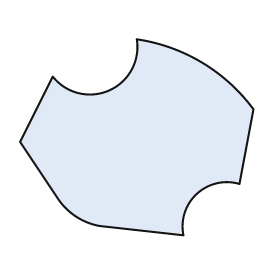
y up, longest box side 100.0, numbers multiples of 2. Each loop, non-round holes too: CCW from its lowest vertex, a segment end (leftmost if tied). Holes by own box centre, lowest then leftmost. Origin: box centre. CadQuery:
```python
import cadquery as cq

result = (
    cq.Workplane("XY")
    .moveTo(20.0, -42.0)
    .threePointArc((26.0, -24.0), (44.0, -20.0))
    .lineTo(50.0, 12.0)
    .threePointArc((28.0, 32.0), (0.0, 42.0))
    .threePointArc((-12.0, 20.0), (-36.0, 26.0))
    .lineTo(-50.0, -2.0)
    .lineTo(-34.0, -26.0)
    .threePointArc((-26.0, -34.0), (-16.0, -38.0))
    .close()
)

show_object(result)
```